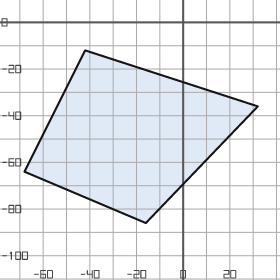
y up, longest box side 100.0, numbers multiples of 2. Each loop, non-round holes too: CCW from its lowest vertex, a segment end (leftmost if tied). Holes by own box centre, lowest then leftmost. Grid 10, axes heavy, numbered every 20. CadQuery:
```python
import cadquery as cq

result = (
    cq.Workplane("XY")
    .moveTo(-16.0, -86.0)
    .lineTo(32.0, -36.0)
    .lineTo(-42.0, -12.0)
    .lineTo(-68.0, -64.0)
    .close()
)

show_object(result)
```